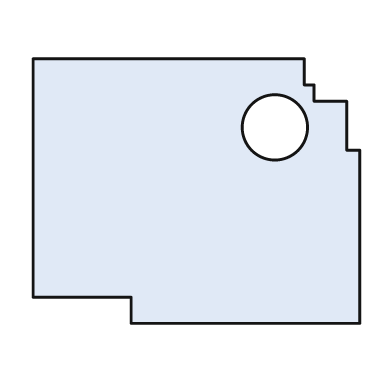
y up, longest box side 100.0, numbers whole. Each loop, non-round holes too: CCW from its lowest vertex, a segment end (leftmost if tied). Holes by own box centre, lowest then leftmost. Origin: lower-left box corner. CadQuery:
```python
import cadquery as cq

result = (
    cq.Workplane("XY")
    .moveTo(30.0, 0.0)
    .lineTo(100.0, 0.0)
    .lineTo(100.0, 53.0)
    .lineTo(96.0, 53.0)
    .lineTo(96.0, 68.0)
    .lineTo(86.0, 68.0)
    .lineTo(86.0, 73.0)
    .lineTo(83.0, 73.0)
    .lineTo(83.0, 81.0)
    .lineTo(0.0, 81.0)
    .lineTo(0.0, 8.0)
    .lineTo(30.0, 8.0)
    .close()
    .moveTo(74.0, 60.0)
    .circle(10.0)
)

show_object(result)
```